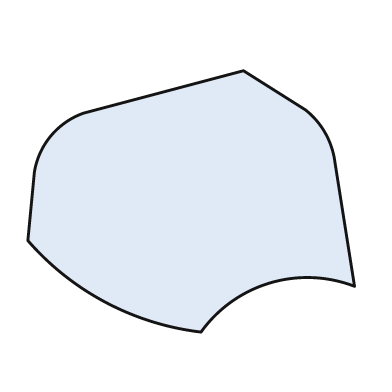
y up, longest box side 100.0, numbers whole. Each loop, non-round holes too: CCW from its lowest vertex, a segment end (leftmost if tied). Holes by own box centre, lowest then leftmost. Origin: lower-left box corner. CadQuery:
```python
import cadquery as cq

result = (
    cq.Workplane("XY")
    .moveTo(53.0, 0.0)
    .threePointArc((74.0, 15.0), (100.0, 14.0))
    .lineTo(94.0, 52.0)
    .threePointArc((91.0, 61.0), (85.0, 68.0))
    .lineTo(66.0, 80.0)
    .lineTo(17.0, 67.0)
    .threePointArc((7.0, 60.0), (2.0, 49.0))
    .lineTo(0.0, 28.0)
    .threePointArc((24.0, 9.0), (53.0, 0.0))
    .close()
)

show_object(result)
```